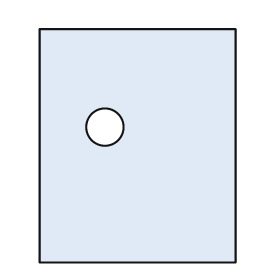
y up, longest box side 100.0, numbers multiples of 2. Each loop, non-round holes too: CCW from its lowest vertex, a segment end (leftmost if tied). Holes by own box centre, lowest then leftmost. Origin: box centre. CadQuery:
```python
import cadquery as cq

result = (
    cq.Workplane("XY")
    .moveTo(-42.0, -50.0)
    .lineTo(42.0, -50.0)
    .lineTo(42.0, 50.0)
    .lineTo(-42.0, 50.0)
    .close()
    .moveTo(-14.0, 8.0)
    .circle(8.0)
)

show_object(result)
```